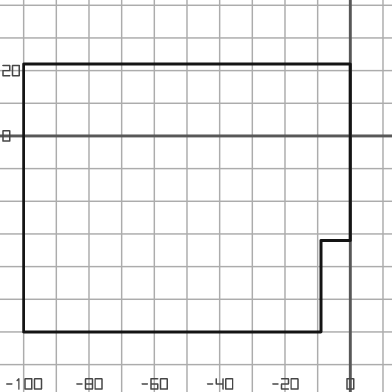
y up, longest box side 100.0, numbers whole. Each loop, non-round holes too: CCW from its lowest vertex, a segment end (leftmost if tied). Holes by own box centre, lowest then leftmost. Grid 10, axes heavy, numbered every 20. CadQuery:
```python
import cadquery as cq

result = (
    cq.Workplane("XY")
    .moveTo(-100.0, -60.0)
    .lineTo(-9.0, -60.0)
    .lineTo(-9.0, -32.0)
    .lineTo(0.0, -32.0)
    .lineTo(0.0, 22.0)
    .lineTo(-100.0, 22.0)
    .close()
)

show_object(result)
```